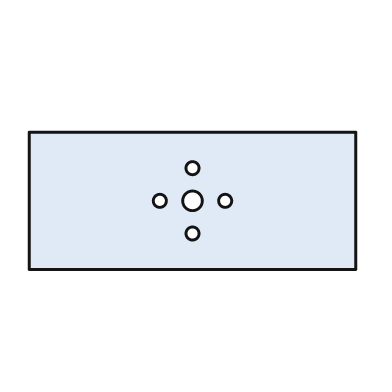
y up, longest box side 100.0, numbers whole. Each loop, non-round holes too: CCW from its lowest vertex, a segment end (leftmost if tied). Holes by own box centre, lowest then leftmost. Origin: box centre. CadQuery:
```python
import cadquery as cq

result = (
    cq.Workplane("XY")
    .moveTo(-50.0, -21.0)
    .lineTo(50.0, -21.0)
    .lineTo(50.0, 21.0)
    .lineTo(-50.0, 21.0)
    .close()
    .moveTo(0.0, -10.0)
    .circle(2.0)
    .moveTo(-10.0, 0.0)
    .circle(2.0)
    .moveTo(0.0, 0.0)
    .circle(3.0)
    .moveTo(10.0, 0.0)
    .circle(2.0)
    .moveTo(0.0, 10.0)
    .circle(2.0)
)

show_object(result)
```